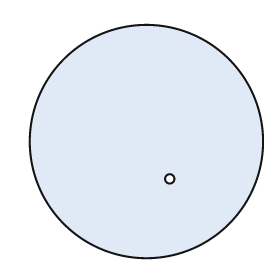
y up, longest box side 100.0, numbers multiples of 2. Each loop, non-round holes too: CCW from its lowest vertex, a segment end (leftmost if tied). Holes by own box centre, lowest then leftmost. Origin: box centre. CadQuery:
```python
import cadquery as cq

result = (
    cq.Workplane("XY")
    .moveTo(0.0, 0.0)
    .circle(50.0)
    .moveTo(10.0, -16.0)
    .circle(2.0)
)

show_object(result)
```